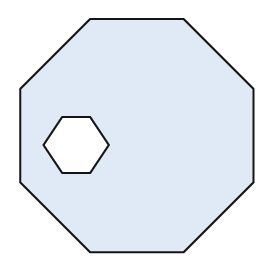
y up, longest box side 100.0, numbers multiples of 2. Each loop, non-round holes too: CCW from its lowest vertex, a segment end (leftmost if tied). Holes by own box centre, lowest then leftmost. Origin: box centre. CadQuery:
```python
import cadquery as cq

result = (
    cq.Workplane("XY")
    .moveTo(-20.0, -50.0)
    .lineTo(20.0, -50.0)
    .lineTo(50.0, -20.0)
    .lineTo(50.0, 20.0)
    .lineTo(20.0, 50.0)
    .lineTo(-20.0, 50.0)
    .lineTo(-50.0, 20.0)
    .lineTo(-50.0, -20.0)
    .close()
    .moveTo(-32.0, -16.0)
    .lineTo(-20.0, -16.0)
    .lineTo(-12.0, -4.0)
    .lineTo(-20.0, 8.0)
    .lineTo(-32.0, 8.0)
    .lineTo(-40.0, -4.0)
    .close()
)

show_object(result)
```